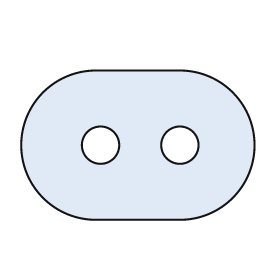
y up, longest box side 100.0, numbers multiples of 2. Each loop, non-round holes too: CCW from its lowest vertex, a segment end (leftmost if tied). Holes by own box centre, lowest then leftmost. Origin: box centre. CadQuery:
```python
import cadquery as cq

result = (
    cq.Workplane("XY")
    .moveTo(-18.0, -32.0)
    .lineTo(18.0, -32.0)
    .threePointArc((50.0, 0.0), (18.0, 32.0))
    .lineTo(-18.0, 32.0)
    .threePointArc((-50.0, 0.0), (-18.0, -32.0))
    .close()
    .moveTo(-16.0, 0.0)
    .circle(8.0)
    .moveTo(18.0, 0.0)
    .circle(8.0)
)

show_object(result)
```